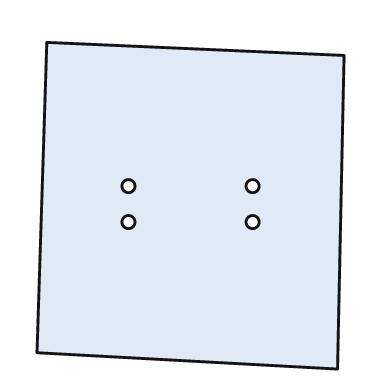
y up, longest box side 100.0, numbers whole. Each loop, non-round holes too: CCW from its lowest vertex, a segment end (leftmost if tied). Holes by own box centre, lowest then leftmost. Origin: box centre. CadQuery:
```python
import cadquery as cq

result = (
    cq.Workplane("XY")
    .moveTo(45.0, -50.0)
    .lineTo(47.0, 46.0)
    .lineTo(-44.0, 50.0)
    .lineTo(-47.0, -45.0)
    .close()
    .moveTo(-19.0, -5.0)
    .circle(2.0)
    .moveTo(19.0, -5.0)
    .circle(2.0)
    .moveTo(-19.0, 6.0)
    .circle(2.0)
    .moveTo(19.0, 6.0)
    .circle(2.0)
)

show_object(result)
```